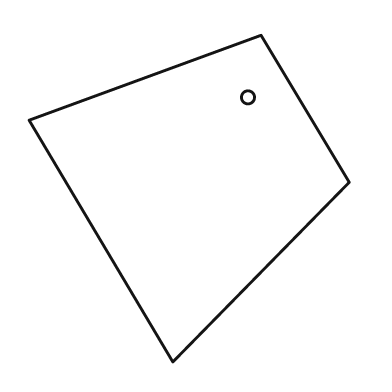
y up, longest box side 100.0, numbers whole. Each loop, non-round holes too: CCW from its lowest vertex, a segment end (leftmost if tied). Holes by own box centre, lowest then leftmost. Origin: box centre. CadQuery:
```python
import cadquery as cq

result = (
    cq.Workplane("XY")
    .moveTo(-5.0, -50.0)
    .lineTo(49.0, 5.0)
    .lineTo(22.0, 50.0)
    .lineTo(-49.0, 24.0)
    .close()
    .moveTo(18.0, 31.0)
    .circle(2.0)
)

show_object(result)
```